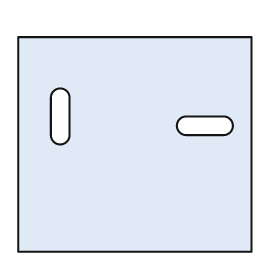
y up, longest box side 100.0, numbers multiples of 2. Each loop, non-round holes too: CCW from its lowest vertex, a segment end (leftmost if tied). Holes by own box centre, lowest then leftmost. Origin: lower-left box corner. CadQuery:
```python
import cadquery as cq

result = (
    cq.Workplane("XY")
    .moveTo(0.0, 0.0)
    .lineTo(100.0, 0.0)
    .lineTo(100.0, 92.0)
    .lineTo(0.0, 92.0)
    .close()
    .moveTo(72.0, 50.0)
    .lineTo(88.0, 50.0)
    .threePointArc((92.0, 54.0), (88.0, 58.0))
    .lineTo(72.0, 58.0)
    .threePointArc((68.0, 54.0), (72.0, 50.0))
    .close()
    .moveTo(14.0, 50.0)
    .threePointArc((18.0, 46.0), (22.0, 50.0))
    .lineTo(22.0, 66.0)
    .threePointArc((18.0, 70.0), (14.0, 66.0))
    .close()
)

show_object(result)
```